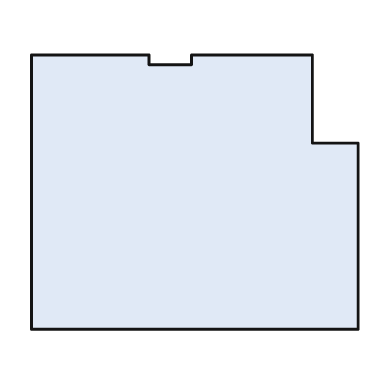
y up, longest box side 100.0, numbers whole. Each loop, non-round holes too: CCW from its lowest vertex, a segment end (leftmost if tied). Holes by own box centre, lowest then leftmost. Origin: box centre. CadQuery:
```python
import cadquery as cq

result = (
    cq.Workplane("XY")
    .moveTo(-50.0, -42.0)
    .lineTo(50.0, -42.0)
    .lineTo(50.0, 15.0)
    .lineTo(36.0, 15.0)
    .lineTo(36.0, 42.0)
    .lineTo(-1.0, 42.0)
    .lineTo(-1.0, 39.0)
    .lineTo(-14.0, 39.0)
    .lineTo(-14.0, 42.0)
    .lineTo(-50.0, 42.0)
    .close()
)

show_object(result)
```